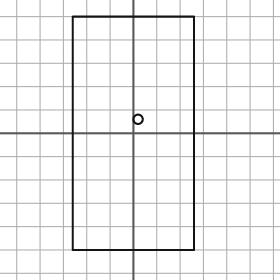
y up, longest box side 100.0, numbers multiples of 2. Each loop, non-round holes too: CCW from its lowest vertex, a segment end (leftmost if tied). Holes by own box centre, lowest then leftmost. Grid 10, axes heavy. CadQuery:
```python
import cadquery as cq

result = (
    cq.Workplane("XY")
    .moveTo(-26.0, -50.0)
    .lineTo(26.0, -50.0)
    .lineTo(26.0, 50.0)
    .lineTo(-26.0, 50.0)
    .close()
    .moveTo(2.0, 6.0)
    .circle(2.0)
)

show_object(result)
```